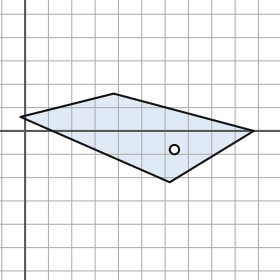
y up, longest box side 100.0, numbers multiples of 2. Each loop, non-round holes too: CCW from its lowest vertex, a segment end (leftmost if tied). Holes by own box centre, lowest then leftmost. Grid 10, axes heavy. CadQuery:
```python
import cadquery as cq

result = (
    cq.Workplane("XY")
    .moveTo(62.0, -22.0)
    .lineTo(98.0, 0.0)
    .lineTo(38.0, 16.0)
    .lineTo(-2.0, 6.0)
    .close()
    .moveTo(64.0, -8.0)
    .circle(2.0)
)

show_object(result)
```